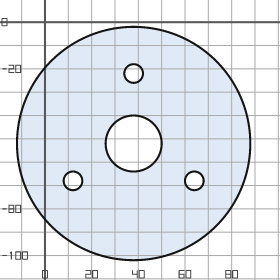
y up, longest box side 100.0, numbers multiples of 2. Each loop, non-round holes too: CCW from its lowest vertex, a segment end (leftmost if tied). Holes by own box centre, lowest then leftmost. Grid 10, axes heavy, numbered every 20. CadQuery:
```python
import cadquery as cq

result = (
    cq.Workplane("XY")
    .moveTo(38.0, -52.0)
    .circle(50.0)
    .moveTo(12.0, -68.0)
    .circle(4.0)
    .moveTo(64.0, -68.0)
    .circle(4.0)
    .moveTo(38.0, -52.0)
    .circle(12.0)
    .moveTo(38.0, -22.0)
    .circle(4.0)
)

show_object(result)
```